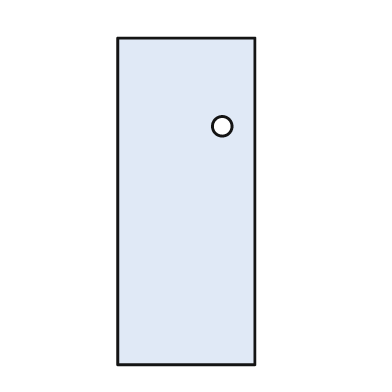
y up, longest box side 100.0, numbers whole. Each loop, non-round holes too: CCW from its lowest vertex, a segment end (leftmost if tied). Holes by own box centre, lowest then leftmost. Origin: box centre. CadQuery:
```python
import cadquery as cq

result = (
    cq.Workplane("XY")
    .moveTo(-21.0, -50.0)
    .lineTo(21.0, -50.0)
    .lineTo(21.0, 50.0)
    .lineTo(-21.0, 50.0)
    .close()
    .moveTo(11.0, 23.0)
    .circle(3.0)
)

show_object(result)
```